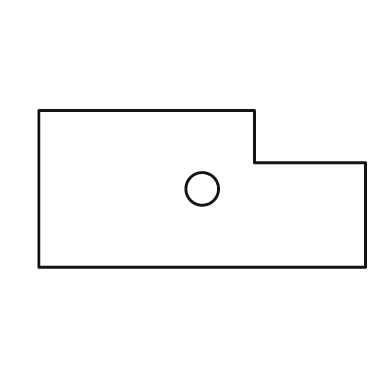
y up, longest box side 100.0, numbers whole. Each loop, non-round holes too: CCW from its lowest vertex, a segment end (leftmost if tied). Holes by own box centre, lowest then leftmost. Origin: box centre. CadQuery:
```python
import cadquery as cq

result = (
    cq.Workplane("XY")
    .moveTo(-50.0, -24.0)
    .lineTo(50.0, -24.0)
    .lineTo(50.0, 8.0)
    .lineTo(16.0, 8.0)
    .lineTo(16.0, 24.0)
    .lineTo(-50.0, 24.0)
    .close()
    .moveTo(0.0, 0.0)
    .circle(5.0)
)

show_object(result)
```